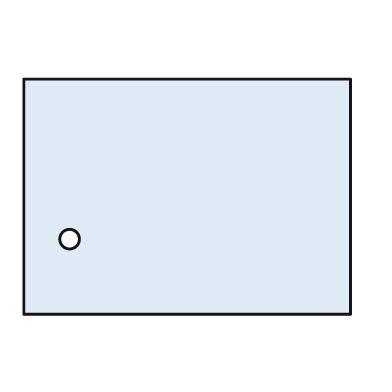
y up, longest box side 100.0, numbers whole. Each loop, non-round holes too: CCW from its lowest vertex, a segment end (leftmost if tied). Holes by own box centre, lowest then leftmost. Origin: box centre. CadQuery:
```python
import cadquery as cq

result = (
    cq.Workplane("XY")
    .moveTo(-50.0, -36.0)
    .lineTo(50.0, -36.0)
    .lineTo(50.0, 36.0)
    .lineTo(-50.0, 36.0)
    .close()
    .moveTo(-36.0, -13.0)
    .circle(3.0)
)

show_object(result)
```